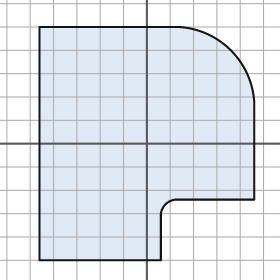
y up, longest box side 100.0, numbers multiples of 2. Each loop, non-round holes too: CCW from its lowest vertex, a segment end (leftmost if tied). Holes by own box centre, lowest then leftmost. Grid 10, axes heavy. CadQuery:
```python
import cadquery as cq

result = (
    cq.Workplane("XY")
    .moveTo(-46.0, -50.0)
    .lineTo(6.0, -50.0)
    .lineTo(6.0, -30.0)
    .threePointArc((8.0, -26.0), (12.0, -24.0))
    .lineTo(46.0, -24.0)
    .lineTo(46.0, 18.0)
    .threePointArc((36.0, 40.0), (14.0, 50.0))
    .lineTo(-46.0, 50.0)
    .close()
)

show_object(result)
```